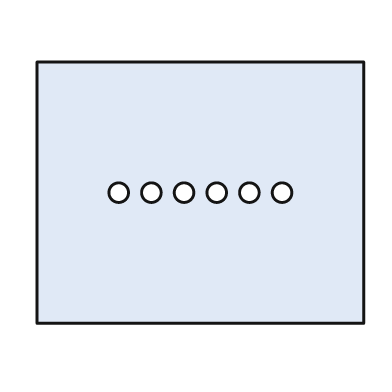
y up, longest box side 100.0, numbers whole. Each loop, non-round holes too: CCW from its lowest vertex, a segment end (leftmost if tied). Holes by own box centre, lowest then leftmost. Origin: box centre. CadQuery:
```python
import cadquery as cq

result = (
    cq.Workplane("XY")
    .moveTo(-50.0, -40.0)
    .lineTo(50.0, -40.0)
    .lineTo(50.0, 40.0)
    .lineTo(-50.0, 40.0)
    .close()
    .moveTo(-25.0, 0.0)
    .circle(3.0)
    .moveTo(-15.0, 0.0)
    .circle(3.0)
    .moveTo(-5.0, 0.0)
    .circle(3.0)
    .moveTo(5.0, 0.0)
    .circle(3.0)
    .moveTo(15.0, 0.0)
    .circle(3.0)
    .moveTo(25.0, 0.0)
    .circle(3.0)
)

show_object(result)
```